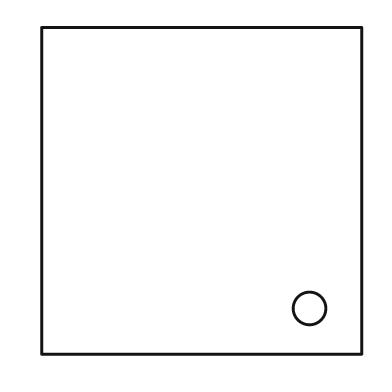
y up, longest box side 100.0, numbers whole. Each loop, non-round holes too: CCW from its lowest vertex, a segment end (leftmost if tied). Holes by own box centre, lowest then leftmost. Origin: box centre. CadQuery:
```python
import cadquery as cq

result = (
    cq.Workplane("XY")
    .moveTo(-49.0, -50.0)
    .lineTo(49.0, -50.0)
    .lineTo(49.0, 50.0)
    .lineTo(-49.0, 50.0)
    .close()
    .moveTo(33.0, -36.0)
    .circle(5.0)
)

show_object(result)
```